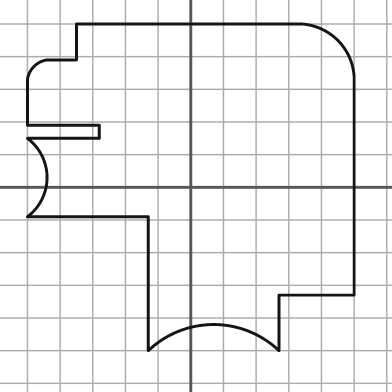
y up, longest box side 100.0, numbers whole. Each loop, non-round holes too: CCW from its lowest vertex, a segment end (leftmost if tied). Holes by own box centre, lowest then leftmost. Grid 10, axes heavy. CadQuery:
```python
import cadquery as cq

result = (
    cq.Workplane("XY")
    .moveTo(-13.0, -50.0)
    .threePointArc((7.0, -42.0), (27.0, -50.0))
    .lineTo(27.0, -33.0)
    .lineTo(50.0, -33.0)
    .lineTo(50.0, 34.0)
    .threePointArc((45.0, 45.0), (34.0, 50.0))
    .lineTo(-35.0, 50.0)
    .lineTo(-35.0, 39.0)
    .lineTo(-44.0, 39.0)
    .threePointArc((-48.0, 37.0), (-50.0, 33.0))
    .lineTo(-50.0, 19.0)
    .lineTo(-28.0, 19.0)
    .lineTo(-28.0, 15.0)
    .lineTo(-50.0, 15.0)
    .threePointArc((-44.0, 3.0), (-50.0, -9.0))
    .lineTo(-13.0, -9.0)
    .close()
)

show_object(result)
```